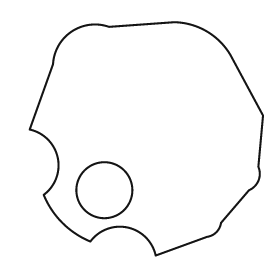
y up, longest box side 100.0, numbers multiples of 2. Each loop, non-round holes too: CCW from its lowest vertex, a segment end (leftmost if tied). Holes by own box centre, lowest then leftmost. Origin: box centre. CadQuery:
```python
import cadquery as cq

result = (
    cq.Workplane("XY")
    .moveTo(4.0, -50.0)
    .lineTo(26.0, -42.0)
    .threePointArc((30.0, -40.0), (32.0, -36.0))
    .lineTo(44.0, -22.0)
    .threePointArc((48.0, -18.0), (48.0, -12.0))
    .lineTo(50.0, 10.0)
    .lineTo(36.0, 36.0)
    .threePointArc((26.0, 46.0), (12.0, 50.0))
    .lineTo(-16.0, 48.0)
    .threePointArc((-32.0, 46.0), (-40.0, 32.0))
    .lineTo(-50.0, 4.0)
    .threePointArc((-38.0, -8.0), (-44.0, -24.0))
    .threePointArc((-36.0, -36.0), (-24.0, -44.0))
    .threePointArc((-8.0, -38.0), (4.0, -50.0))
    .close()
    .moveTo(-18.0, -22.0)
    .circle(12.0)
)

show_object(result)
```